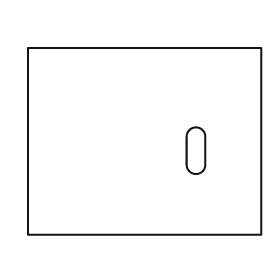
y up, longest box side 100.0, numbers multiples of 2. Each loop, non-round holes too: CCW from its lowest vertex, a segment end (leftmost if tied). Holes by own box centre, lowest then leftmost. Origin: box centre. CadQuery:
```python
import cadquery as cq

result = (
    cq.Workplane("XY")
    .moveTo(-50.0, -40.0)
    .lineTo(50.0, -40.0)
    .lineTo(50.0, 40.0)
    .lineTo(-50.0, 40.0)
    .close()
    .moveTo(18.0, -10.0)
    .threePointArc((22.0, -14.0), (26.0, -10.0))
    .lineTo(26.0, 2.0)
    .threePointArc((22.0, 6.0), (18.0, 2.0))
    .close()
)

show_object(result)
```